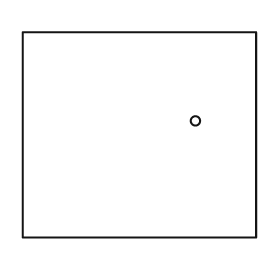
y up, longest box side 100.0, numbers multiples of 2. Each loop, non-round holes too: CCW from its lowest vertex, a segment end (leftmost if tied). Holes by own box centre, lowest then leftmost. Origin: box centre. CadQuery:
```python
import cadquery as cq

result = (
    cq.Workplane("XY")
    .moveTo(-50.0, -44.0)
    .lineTo(50.0, -44.0)
    .lineTo(50.0, 44.0)
    .lineTo(-50.0, 44.0)
    .close()
    .moveTo(24.0, 6.0)
    .circle(2.0)
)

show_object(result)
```